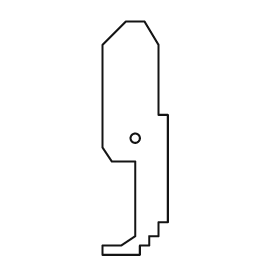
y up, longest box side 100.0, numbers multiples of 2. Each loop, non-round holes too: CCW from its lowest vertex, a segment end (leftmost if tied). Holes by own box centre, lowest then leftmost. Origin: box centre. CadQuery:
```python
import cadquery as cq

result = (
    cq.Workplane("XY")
    .moveTo(-14.0, -50.0)
    .lineTo(2.0, -50.0)
    .lineTo(2.0, -46.0)
    .lineTo(6.0, -46.0)
    .lineTo(6.0, -42.0)
    .lineTo(10.0, -42.0)
    .lineTo(10.0, -36.0)
    .lineTo(14.0, -36.0)
    .lineTo(14.0, 10.0)
    .lineTo(10.0, 10.0)
    .lineTo(10.0, 40.0)
    .lineTo(4.0, 50.0)
    .lineTo(-4.0, 50.0)
    .lineTo(-14.0, 40.0)
    .lineTo(-14.0, -4.0)
    .lineTo(-10.0, -10.0)
    .lineTo(0.0, -10.0)
    .lineTo(0.0, -42.0)
    .lineTo(-6.0, -46.0)
    .lineTo(-14.0, -46.0)
    .close()
    .moveTo(0.0, 0.0)
    .circle(2.0)
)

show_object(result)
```